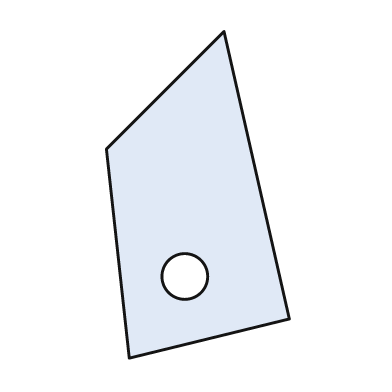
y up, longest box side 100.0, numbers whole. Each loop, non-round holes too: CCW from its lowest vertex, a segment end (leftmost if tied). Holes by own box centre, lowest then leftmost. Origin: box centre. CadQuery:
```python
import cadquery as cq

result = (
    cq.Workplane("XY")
    .moveTo(-21.0, -50.0)
    .lineTo(28.0, -38.0)
    .lineTo(8.0, 50.0)
    .lineTo(-28.0, 14.0)
    .close()
    .moveTo(-4.0, -25.0)
    .circle(7.0)
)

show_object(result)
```